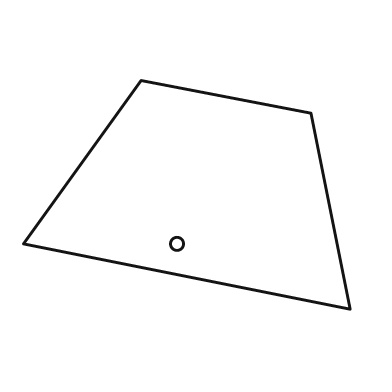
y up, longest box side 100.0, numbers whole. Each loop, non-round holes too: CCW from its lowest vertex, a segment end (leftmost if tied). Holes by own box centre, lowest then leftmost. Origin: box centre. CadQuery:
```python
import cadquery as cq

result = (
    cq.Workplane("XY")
    .moveTo(50.0, -35.0)
    .lineTo(38.0, 25.0)
    .lineTo(-14.0, 35.0)
    .lineTo(-50.0, -15.0)
    .close()
    .moveTo(-3.0, -15.0)
    .circle(2.0)
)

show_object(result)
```